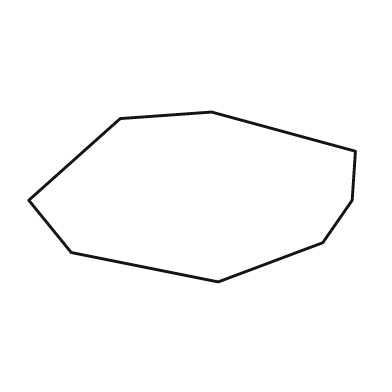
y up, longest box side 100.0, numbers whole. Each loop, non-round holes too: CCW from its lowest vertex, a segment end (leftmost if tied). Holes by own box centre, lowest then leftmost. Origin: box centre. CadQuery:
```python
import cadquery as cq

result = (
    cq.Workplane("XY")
    .moveTo(8.0, -26.0)
    .lineTo(40.0, -14.0)
    .lineTo(49.0, -1.0)
    .lineTo(50.0, 14.0)
    .lineTo(6.0, 26.0)
    .lineTo(-22.0, 24.0)
    .lineTo(-50.0, -1.0)
    .lineTo(-37.0, -17.0)
    .close()
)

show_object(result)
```